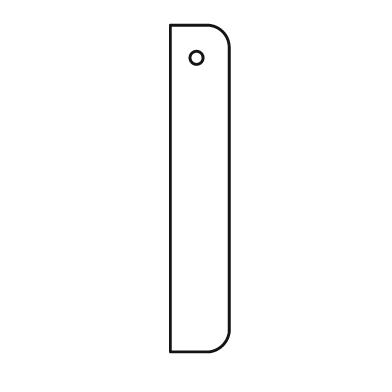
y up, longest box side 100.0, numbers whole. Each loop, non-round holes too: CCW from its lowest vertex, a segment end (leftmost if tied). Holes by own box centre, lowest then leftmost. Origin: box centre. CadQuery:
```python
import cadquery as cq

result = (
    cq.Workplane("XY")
    .moveTo(-9.0, -50.0)
    .lineTo(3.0, -50.0)
    .threePointArc((7.0, -48.0), (9.0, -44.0))
    .lineTo(9.0, 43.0)
    .threePointArc((7.0, 48.0), (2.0, 50.0))
    .lineTo(-9.0, 50.0)
    .close()
    .moveTo(-1.0, 40.0)
    .circle(2.0)
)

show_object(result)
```